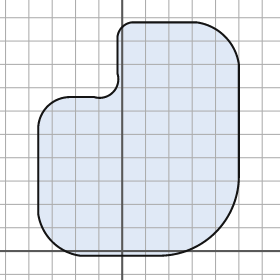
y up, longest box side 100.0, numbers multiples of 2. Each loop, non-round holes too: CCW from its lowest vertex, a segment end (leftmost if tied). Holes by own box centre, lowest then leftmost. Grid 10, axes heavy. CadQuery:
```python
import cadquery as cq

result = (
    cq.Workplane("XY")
    .moveTo(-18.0, -2.0)
    .lineTo(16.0, -2.0)
    .threePointArc((40.0, 8.0), (50.0, 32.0))
    .lineTo(50.0, 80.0)
    .threePointArc((44.0, 92.0), (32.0, 98.0))
    .lineTo(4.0, 98.0)
    .threePointArc((0.0, 96.0), (-2.0, 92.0))
    .lineTo(-2.0, 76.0)
    .threePointArc((-4.0, 68.0), (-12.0, 66.0))
    .lineTo(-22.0, 66.0)
    .threePointArc((-32.0, 62.0), (-36.0, 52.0))
    .lineTo(-36.0, 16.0)
    .threePointArc((-30.0, 4.0), (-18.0, -2.0))
    .close()
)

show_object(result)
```